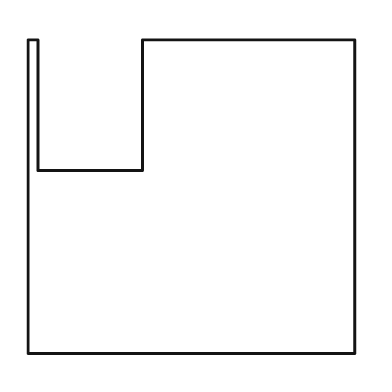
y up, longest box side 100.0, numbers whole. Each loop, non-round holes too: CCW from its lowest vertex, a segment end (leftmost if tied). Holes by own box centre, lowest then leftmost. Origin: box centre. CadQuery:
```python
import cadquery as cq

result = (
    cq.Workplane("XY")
    .moveTo(-50.0, -48.0)
    .lineTo(50.0, -48.0)
    .lineTo(50.0, 48.0)
    .lineTo(-15.0, 48.0)
    .lineTo(-15.0, 8.0)
    .lineTo(-47.0, 8.0)
    .lineTo(-47.0, 48.0)
    .lineTo(-50.0, 48.0)
    .close()
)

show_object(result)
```